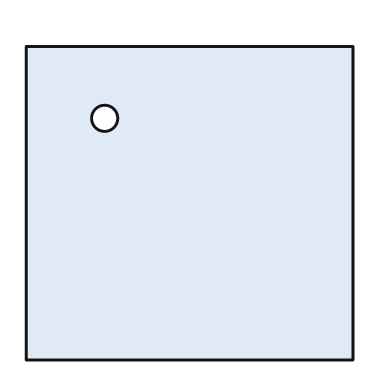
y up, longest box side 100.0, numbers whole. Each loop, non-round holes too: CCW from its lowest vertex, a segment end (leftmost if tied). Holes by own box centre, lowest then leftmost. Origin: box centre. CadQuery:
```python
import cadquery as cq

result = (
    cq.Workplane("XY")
    .moveTo(-50.0, -48.0)
    .lineTo(50.0, -48.0)
    .lineTo(50.0, 48.0)
    .lineTo(-50.0, 48.0)
    .close()
    .moveTo(-26.0, 26.0)
    .circle(4.0)
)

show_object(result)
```